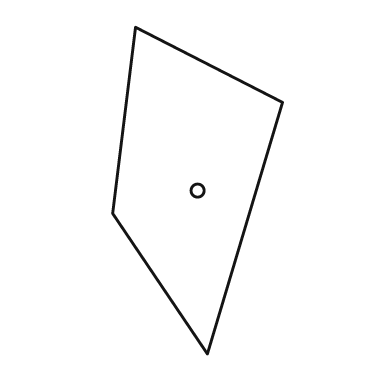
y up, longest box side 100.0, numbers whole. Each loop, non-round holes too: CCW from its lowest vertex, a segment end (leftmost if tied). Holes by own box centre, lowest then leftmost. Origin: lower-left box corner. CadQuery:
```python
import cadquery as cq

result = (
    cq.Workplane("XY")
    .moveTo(29.0, 0.0)
    .lineTo(52.0, 77.0)
    .lineTo(7.0, 100.0)
    .lineTo(0.0, 43.0)
    .close()
    .moveTo(26.0, 50.0)
    .circle(2.0)
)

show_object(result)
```